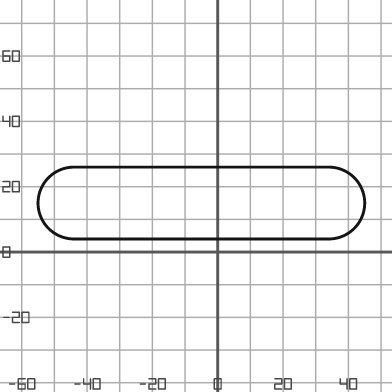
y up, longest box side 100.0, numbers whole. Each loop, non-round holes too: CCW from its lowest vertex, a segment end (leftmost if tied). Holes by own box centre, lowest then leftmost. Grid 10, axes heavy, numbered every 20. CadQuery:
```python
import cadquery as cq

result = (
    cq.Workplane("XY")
    .moveTo(-44.0, 4.0)
    .lineTo(34.0, 4.0)
    .threePointArc((45.0, 15.0), (34.0, 26.0))
    .lineTo(-44.0, 26.0)
    .threePointArc((-55.0, 15.0), (-44.0, 4.0))
    .close()
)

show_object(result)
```